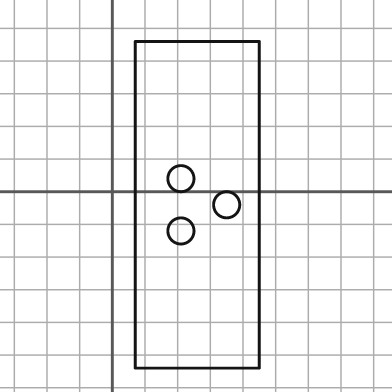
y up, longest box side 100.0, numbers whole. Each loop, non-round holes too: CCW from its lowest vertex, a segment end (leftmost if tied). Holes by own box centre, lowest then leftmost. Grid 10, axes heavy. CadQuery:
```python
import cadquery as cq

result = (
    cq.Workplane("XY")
    .moveTo(7.0, -54.0)
    .lineTo(45.0, -54.0)
    .lineTo(45.0, 46.0)
    .lineTo(7.0, 46.0)
    .close()
    .moveTo(21.0, -12.0)
    .circle(4.0)
    .moveTo(35.0, -4.0)
    .circle(4.0)
    .moveTo(21.0, 4.0)
    .circle(4.0)
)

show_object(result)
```